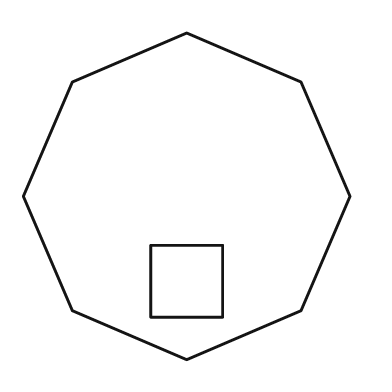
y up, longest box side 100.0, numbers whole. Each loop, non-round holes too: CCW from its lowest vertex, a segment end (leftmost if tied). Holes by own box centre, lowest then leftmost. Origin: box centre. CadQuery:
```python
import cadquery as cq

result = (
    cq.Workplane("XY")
    .moveTo(0.0, -50.0)
    .lineTo(35.0, -35.0)
    .lineTo(50.0, 0.0)
    .lineTo(35.0, 35.0)
    .lineTo(0.0, 50.0)
    .lineTo(-35.0, 35.0)
    .lineTo(-50.0, 0.0)
    .lineTo(-35.0, -35.0)
    .close()
    .moveTo(-11.0, -37.0)
    .lineTo(11.0, -37.0)
    .lineTo(11.0, -15.0)
    .lineTo(-11.0, -15.0)
    .close()
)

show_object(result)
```